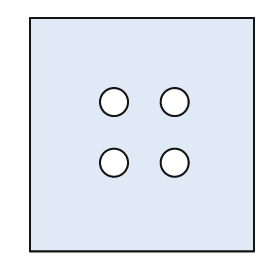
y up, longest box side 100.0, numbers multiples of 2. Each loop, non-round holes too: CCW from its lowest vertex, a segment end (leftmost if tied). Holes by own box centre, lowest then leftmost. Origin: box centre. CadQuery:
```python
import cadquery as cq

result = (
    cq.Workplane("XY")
    .moveTo(-48.0, -50.0)
    .lineTo(48.0, -50.0)
    .lineTo(48.0, 50.0)
    .lineTo(-48.0, 50.0)
    .close()
    .moveTo(-12.0, -12.0)
    .circle(6.0)
    .moveTo(14.0, -12.0)
    .circle(6.0)
    .moveTo(-12.0, 14.0)
    .circle(6.0)
    .moveTo(14.0, 14.0)
    .circle(6.0)
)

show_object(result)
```